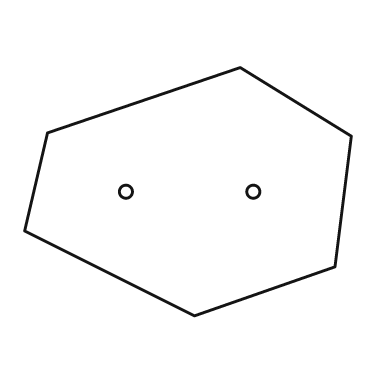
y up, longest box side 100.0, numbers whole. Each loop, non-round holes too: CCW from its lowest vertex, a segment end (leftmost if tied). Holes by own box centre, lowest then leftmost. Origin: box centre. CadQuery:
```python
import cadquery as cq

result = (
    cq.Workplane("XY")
    .moveTo(2.0, -38.0)
    .lineTo(45.0, -23.0)
    .lineTo(50.0, 17.0)
    .lineTo(16.0, 38.0)
    .lineTo(-43.0, 18.0)
    .lineTo(-50.0, -12.0)
    .close()
    .moveTo(-19.0, 0.0)
    .circle(2.0)
    .moveTo(20.0, 0.0)
    .circle(2.0)
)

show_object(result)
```